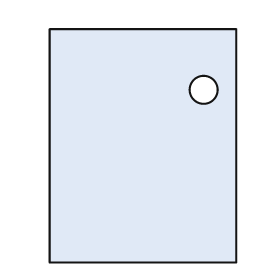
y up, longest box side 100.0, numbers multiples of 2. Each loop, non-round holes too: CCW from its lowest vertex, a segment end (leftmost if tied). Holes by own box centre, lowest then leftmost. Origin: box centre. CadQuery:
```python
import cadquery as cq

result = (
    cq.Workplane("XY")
    .moveTo(-40.0, -50.0)
    .lineTo(40.0, -50.0)
    .lineTo(40.0, 50.0)
    .lineTo(-40.0, 50.0)
    .close()
    .moveTo(26.0, 24.0)
    .circle(6.0)
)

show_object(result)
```